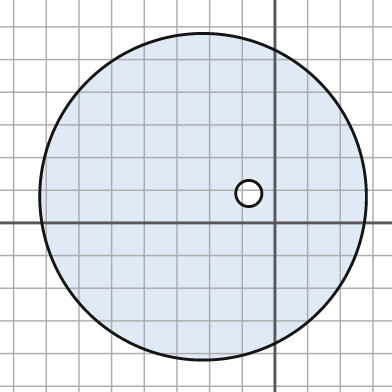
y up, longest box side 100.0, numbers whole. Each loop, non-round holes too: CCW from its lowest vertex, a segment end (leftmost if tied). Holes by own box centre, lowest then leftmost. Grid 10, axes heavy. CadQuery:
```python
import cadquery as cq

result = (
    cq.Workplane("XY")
    .moveTo(-22.0, 8.0)
    .circle(50.0)
    .moveTo(-8.0, 9.0)
    .circle(4.0)
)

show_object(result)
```